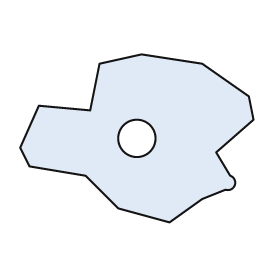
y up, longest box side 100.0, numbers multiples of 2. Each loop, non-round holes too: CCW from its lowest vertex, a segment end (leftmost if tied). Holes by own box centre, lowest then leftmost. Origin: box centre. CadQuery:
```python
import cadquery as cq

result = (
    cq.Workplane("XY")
    .moveTo(14.0, -36.0)
    .lineTo(28.0, -26.0)
    .lineTo(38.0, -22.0)
    .threePointArc((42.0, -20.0), (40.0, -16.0))
    .lineTo(34.0, -6.0)
    .lineTo(50.0, 8.0)
    .lineTo(48.0, 18.0)
    .lineTo(28.0, 32.0)
    .lineTo(2.0, 36.0)
    .lineTo(-16.0, 32.0)
    .lineTo(-20.0, 12.0)
    .lineTo(-42.0, 14.0)
    .lineTo(-50.0, -4.0)
    .lineTo(-46.0, -12.0)
    .lineTo(-22.0, -16.0)
    .lineTo(-8.0, -30.0)
    .close()
    .moveTo(0.0, 0.0)
    .circle(8.0)
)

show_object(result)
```